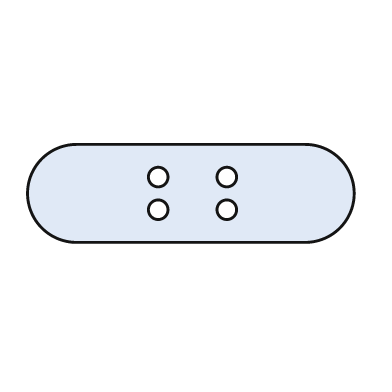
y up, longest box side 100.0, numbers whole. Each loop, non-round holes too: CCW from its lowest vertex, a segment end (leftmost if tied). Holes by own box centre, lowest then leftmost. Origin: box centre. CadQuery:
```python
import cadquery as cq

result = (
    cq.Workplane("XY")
    .moveTo(-35.0, -15.0)
    .lineTo(35.0, -15.0)
    .threePointArc((50.0, 0.0), (35.0, 15.0))
    .lineTo(-35.0, 15.0)
    .threePointArc((-50.0, 0.0), (-35.0, -15.0))
    .close()
    .moveTo(-10.0, -5.0)
    .circle(3.0)
    .moveTo(11.0, -5.0)
    .circle(3.0)
    .moveTo(-10.0, 5.0)
    .circle(3.0)
    .moveTo(11.0, 5.0)
    .circle(3.0)
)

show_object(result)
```